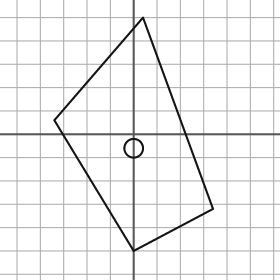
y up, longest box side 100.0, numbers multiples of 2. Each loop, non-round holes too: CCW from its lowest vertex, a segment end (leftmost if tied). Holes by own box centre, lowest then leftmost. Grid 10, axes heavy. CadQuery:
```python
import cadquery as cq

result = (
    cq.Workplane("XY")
    .moveTo(0.0, -50.0)
    .lineTo(34.0, -32.0)
    .lineTo(4.0, 50.0)
    .lineTo(-34.0, 6.0)
    .close()
    .moveTo(0.0, -6.0)
    .circle(4.0)
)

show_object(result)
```